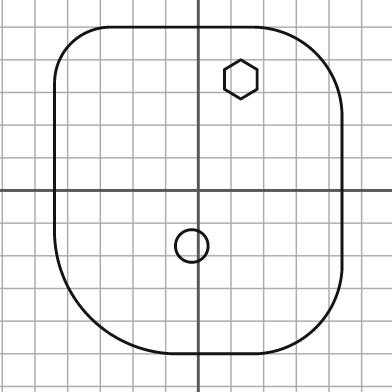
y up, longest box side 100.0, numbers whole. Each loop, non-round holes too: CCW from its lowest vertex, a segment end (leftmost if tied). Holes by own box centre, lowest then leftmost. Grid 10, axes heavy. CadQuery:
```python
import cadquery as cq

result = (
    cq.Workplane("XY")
    .moveTo(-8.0, -50.0)
    .lineTo(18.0, -50.0)
    .threePointArc((36.0, -42.0), (44.0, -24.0))
    .lineTo(44.0, 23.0)
    .threePointArc((36.0, 42.0), (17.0, 50.0))
    .lineTo(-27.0, 50.0)
    .threePointArc((-39.0, 45.0), (-44.0, 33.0))
    .lineTo(-44.0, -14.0)
    .threePointArc((-33.0, -39.0), (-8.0, -50.0))
    .close()
    .moveTo(-2.0, -17.0)
    .circle(5.0)
    .moveTo(13.0, 28.0)
    .lineTo(18.0, 31.0)
    .lineTo(18.0, 37.0)
    .lineTo(13.0, 40.0)
    .lineTo(8.0, 37.0)
    .lineTo(8.0, 31.0)
    .close()
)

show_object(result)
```